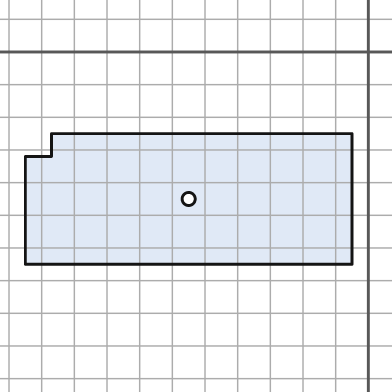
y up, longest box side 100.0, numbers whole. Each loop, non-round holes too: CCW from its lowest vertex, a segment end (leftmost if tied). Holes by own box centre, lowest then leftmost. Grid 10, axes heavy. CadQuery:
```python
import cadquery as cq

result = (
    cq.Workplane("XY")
    .moveTo(-105.0, -65.0)
    .lineTo(-5.0, -65.0)
    .lineTo(-5.0, -25.0)
    .lineTo(-97.0, -25.0)
    .lineTo(-97.0, -32.0)
    .lineTo(-105.0, -32.0)
    .close()
    .moveTo(-55.0, -45.0)
    .circle(2.0)
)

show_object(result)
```